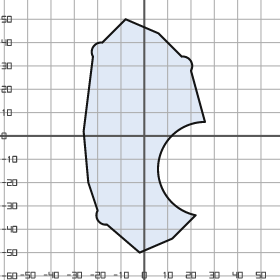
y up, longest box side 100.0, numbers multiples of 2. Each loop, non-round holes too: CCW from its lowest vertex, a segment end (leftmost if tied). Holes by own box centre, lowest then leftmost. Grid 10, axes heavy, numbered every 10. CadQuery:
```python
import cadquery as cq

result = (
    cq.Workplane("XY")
    .moveTo(-2.0, -50.0)
    .lineTo(12.0, -44.0)
    .lineTo(22.0, -34.0)
    .threePointArc((6.0, -12.0), (26.0, 6.0))
    .lineTo(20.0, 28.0)
    .threePointArc((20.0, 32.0), (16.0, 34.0))
    .lineTo(6.0, 44.0)
    .lineTo(-8.0, 50.0)
    .lineTo(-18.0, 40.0)
    .threePointArc((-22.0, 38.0), (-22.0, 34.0))
    .lineTo(-26.0, 2.0)
    .lineTo(-24.0, -20.0)
    .lineTo(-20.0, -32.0)
    .threePointArc((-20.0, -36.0), (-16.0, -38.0))
    .close()
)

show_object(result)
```